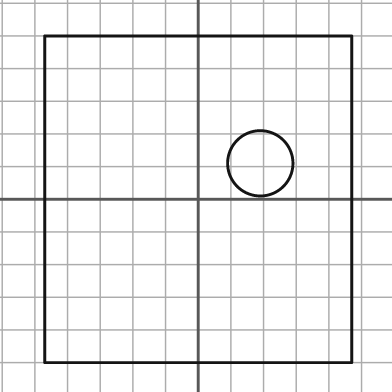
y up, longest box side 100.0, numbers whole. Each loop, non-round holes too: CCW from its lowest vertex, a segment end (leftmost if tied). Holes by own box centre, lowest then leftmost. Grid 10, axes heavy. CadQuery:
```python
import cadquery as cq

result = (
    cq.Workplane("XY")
    .moveTo(-47.0, -50.0)
    .lineTo(47.0, -50.0)
    .lineTo(47.0, 50.0)
    .lineTo(-47.0, 50.0)
    .close()
    .moveTo(19.0, 11.0)
    .circle(10.0)
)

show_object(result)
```